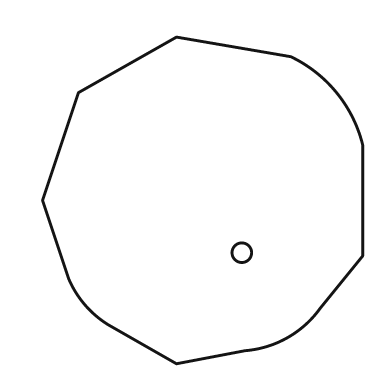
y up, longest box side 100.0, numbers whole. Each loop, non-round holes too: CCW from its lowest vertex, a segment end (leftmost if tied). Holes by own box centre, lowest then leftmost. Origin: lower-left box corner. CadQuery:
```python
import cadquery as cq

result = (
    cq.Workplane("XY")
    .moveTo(41.0, 0.0)
    .lineTo(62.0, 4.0)
    .threePointArc((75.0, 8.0), (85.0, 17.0))
    .lineTo(98.0, 33.0)
    .lineTo(98.0, 67.0)
    .threePointArc((90.0, 83.0), (76.0, 94.0))
    .lineTo(41.0, 100.0)
    .lineTo(11.0, 83.0)
    .lineTo(0.0, 50.0)
    .lineTo(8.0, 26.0)
    .threePointArc((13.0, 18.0), (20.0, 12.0))
    .close()
    .moveTo(61.0, 34.0)
    .circle(3.0)
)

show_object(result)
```